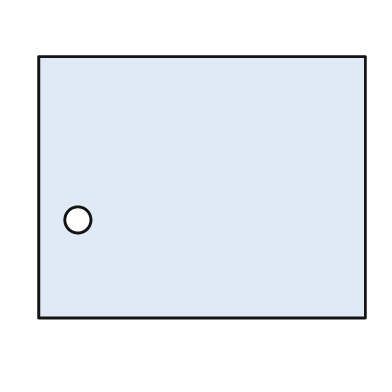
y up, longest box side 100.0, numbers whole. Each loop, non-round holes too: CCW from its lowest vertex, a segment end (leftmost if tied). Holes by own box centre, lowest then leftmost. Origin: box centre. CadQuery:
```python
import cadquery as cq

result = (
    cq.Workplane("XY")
    .moveTo(-50.0, -40.0)
    .lineTo(50.0, -40.0)
    .lineTo(50.0, 40.0)
    .lineTo(-50.0, 40.0)
    .close()
    .moveTo(-38.0, -10.0)
    .circle(4.0)
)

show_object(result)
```